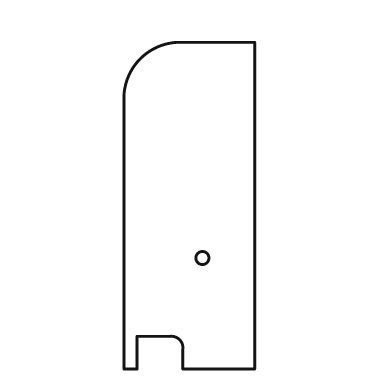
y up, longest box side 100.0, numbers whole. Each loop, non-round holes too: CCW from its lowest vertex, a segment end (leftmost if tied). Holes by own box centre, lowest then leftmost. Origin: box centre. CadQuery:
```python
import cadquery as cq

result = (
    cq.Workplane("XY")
    .moveTo(-20.0, -50.0)
    .lineTo(-16.0, -50.0)
    .lineTo(-16.0, -40.0)
    .lineTo(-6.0, -40.0)
    .threePointArc((-3.0, -41.0), (-2.0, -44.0))
    .lineTo(-2.0, -50.0)
    .lineTo(20.0, -50.0)
    .lineTo(20.0, 50.0)
    .lineTo(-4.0, 50.0)
    .threePointArc((-15.0, 45.0), (-20.0, 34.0))
    .close()
    .moveTo(4.0, -16.0)
    .circle(2.0)
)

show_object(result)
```